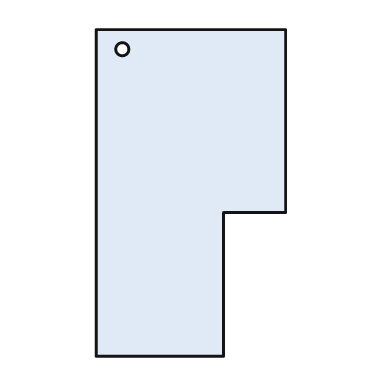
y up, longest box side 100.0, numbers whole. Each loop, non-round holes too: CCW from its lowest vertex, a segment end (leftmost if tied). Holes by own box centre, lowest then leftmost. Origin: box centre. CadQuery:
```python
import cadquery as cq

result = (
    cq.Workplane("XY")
    .moveTo(-29.0, -50.0)
    .lineTo(10.0, -50.0)
    .lineTo(10.0, -6.0)
    .lineTo(29.0, -6.0)
    .lineTo(29.0, 50.0)
    .lineTo(-29.0, 50.0)
    .close()
    .moveTo(-21.0, 44.0)
    .circle(2.0)
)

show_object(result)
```